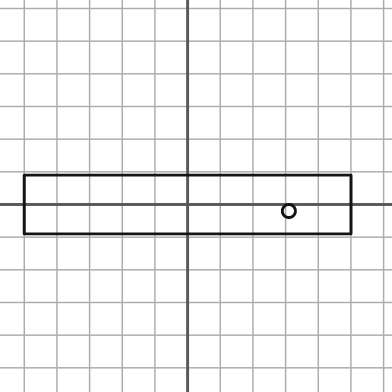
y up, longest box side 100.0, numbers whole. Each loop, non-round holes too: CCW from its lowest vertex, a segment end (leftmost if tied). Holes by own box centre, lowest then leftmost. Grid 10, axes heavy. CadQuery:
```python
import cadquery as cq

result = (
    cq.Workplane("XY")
    .moveTo(-50.0, -9.0)
    .lineTo(50.0, -9.0)
    .lineTo(50.0, 9.0)
    .lineTo(-50.0, 9.0)
    .close()
    .moveTo(31.0, -2.0)
    .circle(2.0)
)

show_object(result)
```